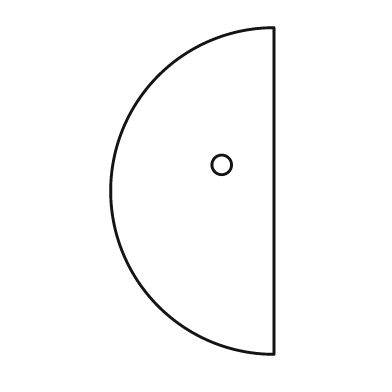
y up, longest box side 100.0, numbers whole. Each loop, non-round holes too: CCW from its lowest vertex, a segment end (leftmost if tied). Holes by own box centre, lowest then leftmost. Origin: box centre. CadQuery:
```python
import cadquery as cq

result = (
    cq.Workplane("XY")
    .moveTo(25.0, -50.0)
    .lineTo(25.0, 50.0)
    .threePointArc((-25.0, 0.0), (25.0, -50.0))
    .close()
    .moveTo(9.0, 8.0)
    .circle(3.0)
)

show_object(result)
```